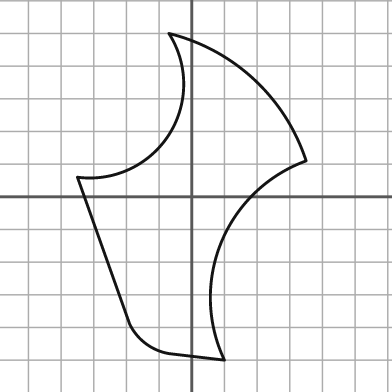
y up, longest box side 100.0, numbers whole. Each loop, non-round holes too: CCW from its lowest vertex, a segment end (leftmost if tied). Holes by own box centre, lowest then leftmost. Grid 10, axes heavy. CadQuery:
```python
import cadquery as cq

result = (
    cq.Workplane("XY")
    .moveTo(10.0, -50.0)
    .threePointArc((9.0, -14.0), (35.0, 11.0))
    .threePointArc((19.0, 36.0), (-7.0, 50.0))
    .threePointArc((-7.0, 19.0), (-35.0, 6.0))
    .lineTo(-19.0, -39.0)
    .threePointArc((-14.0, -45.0), (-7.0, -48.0))
    .close()
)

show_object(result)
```